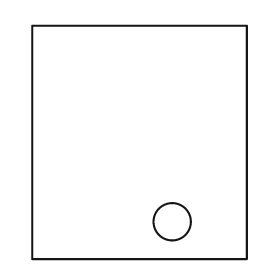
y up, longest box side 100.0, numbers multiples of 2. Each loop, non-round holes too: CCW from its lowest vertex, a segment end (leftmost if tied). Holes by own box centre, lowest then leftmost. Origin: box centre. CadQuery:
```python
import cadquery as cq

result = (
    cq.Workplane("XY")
    .moveTo(-46.0, -50.0)
    .lineTo(46.0, -50.0)
    .lineTo(46.0, 50.0)
    .lineTo(-46.0, 50.0)
    .close()
    .moveTo(14.0, -34.0)
    .circle(8.0)
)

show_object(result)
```